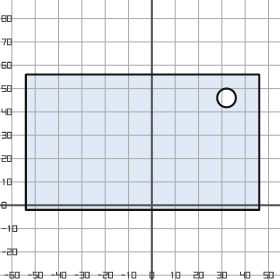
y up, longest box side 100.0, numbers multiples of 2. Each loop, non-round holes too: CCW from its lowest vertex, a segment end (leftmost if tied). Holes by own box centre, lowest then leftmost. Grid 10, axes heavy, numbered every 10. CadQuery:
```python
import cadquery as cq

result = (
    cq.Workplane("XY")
    .moveTo(-54.0, -2.0)
    .lineTo(46.0, -2.0)
    .lineTo(46.0, 56.0)
    .lineTo(-54.0, 56.0)
    .close()
    .moveTo(32.0, 46.0)
    .circle(4.0)
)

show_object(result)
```